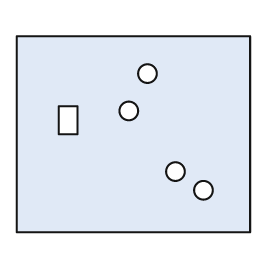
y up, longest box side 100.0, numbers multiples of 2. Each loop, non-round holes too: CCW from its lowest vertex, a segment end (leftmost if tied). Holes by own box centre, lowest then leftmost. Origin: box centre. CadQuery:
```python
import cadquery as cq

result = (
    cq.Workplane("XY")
    .moveTo(-50.0, -42.0)
    .lineTo(50.0, -42.0)
    .lineTo(50.0, 42.0)
    .lineTo(-50.0, 42.0)
    .close()
    .moveTo(30.0, -24.0)
    .circle(4.0)
    .moveTo(18.0, -16.0)
    .circle(4.0)
    .moveTo(-32.0, 0.0)
    .lineTo(-24.0, 0.0)
    .lineTo(-24.0, 12.0)
    .lineTo(-32.0, 12.0)
    .close()
    .moveTo(-2.0, 10.0)
    .circle(4.0)
    .moveTo(6.0, 26.0)
    .circle(4.0)
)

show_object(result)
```